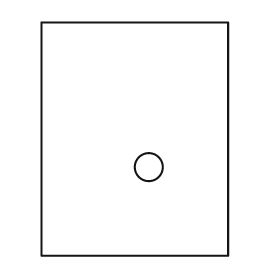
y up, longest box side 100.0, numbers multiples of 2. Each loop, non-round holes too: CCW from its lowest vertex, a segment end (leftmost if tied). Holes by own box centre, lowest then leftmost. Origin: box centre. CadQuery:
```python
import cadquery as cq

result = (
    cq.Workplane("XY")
    .moveTo(-40.0, -50.0)
    .lineTo(40.0, -50.0)
    .lineTo(40.0, 50.0)
    .lineTo(-40.0, 50.0)
    .close()
    .moveTo(6.0, -12.0)
    .circle(6.0)
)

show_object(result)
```